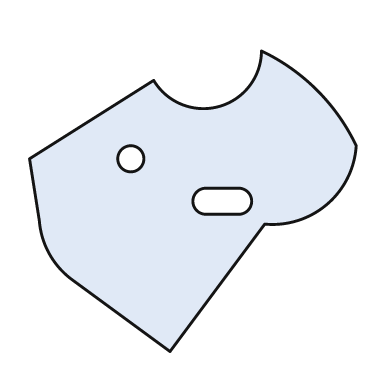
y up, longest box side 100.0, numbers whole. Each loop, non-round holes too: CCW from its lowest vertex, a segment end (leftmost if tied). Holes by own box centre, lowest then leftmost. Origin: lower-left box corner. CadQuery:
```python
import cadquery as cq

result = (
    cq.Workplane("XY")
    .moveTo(43.0, 0.0)
    .lineTo(72.0, 39.0)
    .threePointArc((91.0, 45.0), (100.0, 63.0))
    .threePointArc((88.0, 80.0), (71.0, 92.0))
    .threePointArc((58.0, 75.0), (38.0, 83.0))
    .lineTo(0.0, 59.0)
    .lineTo(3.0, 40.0)
    .threePointArc((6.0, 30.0), (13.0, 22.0))
    .close()
    .moveTo(54.0, 42.0)
    .lineTo(64.0, 42.0)
    .threePointArc((68.0, 46.0), (64.0, 50.0))
    .lineTo(54.0, 50.0)
    .threePointArc((50.0, 46.0), (54.0, 42.0))
    .close()
    .moveTo(31.0, 59.0)
    .circle(4.0)
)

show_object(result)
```